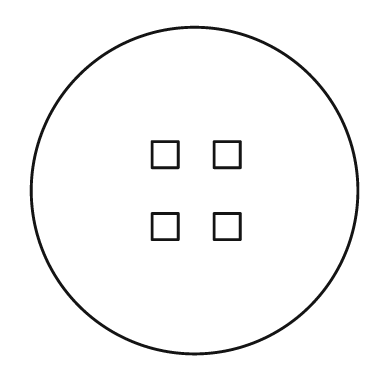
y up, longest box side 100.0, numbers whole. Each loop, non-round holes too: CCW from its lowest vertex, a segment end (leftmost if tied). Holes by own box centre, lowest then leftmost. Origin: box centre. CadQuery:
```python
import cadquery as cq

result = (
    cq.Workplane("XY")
    .moveTo(0.0, 0.0)
    .circle(50.0)
    .moveTo(-13.0, -15.0)
    .lineTo(-5.0, -15.0)
    .lineTo(-5.0, -7.0)
    .lineTo(-13.0, -7.0)
    .close()
    .moveTo(6.0, -15.0)
    .lineTo(14.0, -15.0)
    .lineTo(14.0, -7.0)
    .lineTo(6.0, -7.0)
    .close()
    .moveTo(-13.0, 7.0)
    .lineTo(-5.0, 7.0)
    .lineTo(-5.0, 15.0)
    .lineTo(-13.0, 15.0)
    .close()
    .moveTo(6.0, 7.0)
    .lineTo(14.0, 7.0)
    .lineTo(14.0, 15.0)
    .lineTo(6.0, 15.0)
    .close()
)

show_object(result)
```